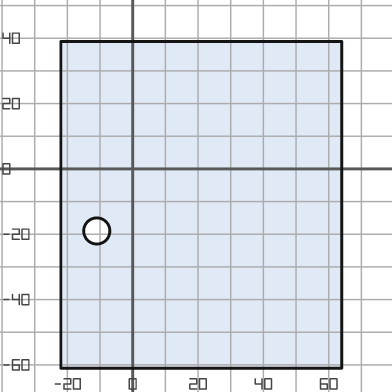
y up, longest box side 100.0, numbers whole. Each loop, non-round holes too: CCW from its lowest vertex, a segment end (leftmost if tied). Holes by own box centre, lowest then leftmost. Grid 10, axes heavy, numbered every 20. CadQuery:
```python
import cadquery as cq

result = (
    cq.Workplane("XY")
    .moveTo(-22.0, -61.0)
    .lineTo(64.0, -61.0)
    .lineTo(64.0, 39.0)
    .lineTo(-22.0, 39.0)
    .close()
    .moveTo(-11.0, -19.0)
    .circle(4.0)
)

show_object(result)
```